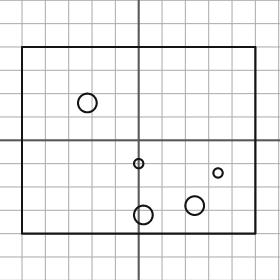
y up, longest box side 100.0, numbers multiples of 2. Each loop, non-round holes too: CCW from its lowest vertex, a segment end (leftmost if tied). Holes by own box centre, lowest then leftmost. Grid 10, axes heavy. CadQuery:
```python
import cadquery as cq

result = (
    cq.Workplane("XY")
    .moveTo(-50.0, -40.0)
    .lineTo(50.0, -40.0)
    .lineTo(50.0, 40.0)
    .lineTo(-50.0, 40.0)
    .close()
    .moveTo(2.0, -32.0)
    .circle(4.0)
    .moveTo(24.0, -28.0)
    .circle(4.0)
    .moveTo(34.0, -14.0)
    .circle(2.0)
    .moveTo(0.0, -10.0)
    .circle(2.0)
    .moveTo(-22.0, 16.0)
    .circle(4.0)
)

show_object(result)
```